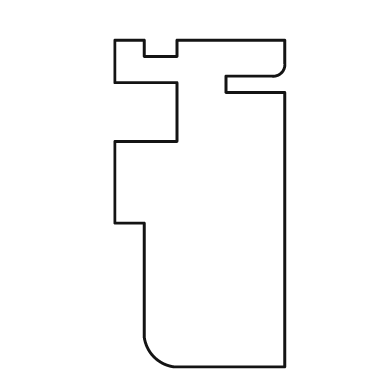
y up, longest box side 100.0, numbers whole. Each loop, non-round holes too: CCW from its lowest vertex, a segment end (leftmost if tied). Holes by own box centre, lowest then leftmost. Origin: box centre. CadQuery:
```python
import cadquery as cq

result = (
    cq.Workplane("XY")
    .moveTo(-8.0, -50.0)
    .lineTo(26.0, -50.0)
    .lineTo(26.0, 34.0)
    .lineTo(8.0, 34.0)
    .lineTo(8.0, 39.0)
    .lineTo(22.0, 39.0)
    .threePointArc((25.0, 40.0), (26.0, 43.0))
    .lineTo(26.0, 50.0)
    .lineTo(-7.0, 50.0)
    .lineTo(-7.0, 45.0)
    .lineTo(-17.0, 45.0)
    .lineTo(-17.0, 50.0)
    .lineTo(-26.0, 50.0)
    .lineTo(-26.0, 37.0)
    .lineTo(-7.0, 37.0)
    .lineTo(-7.0, 19.0)
    .lineTo(-26.0, 19.0)
    .lineTo(-26.0, -6.0)
    .lineTo(-17.0, -6.0)
    .lineTo(-17.0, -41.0)
    .threePointArc((-14.0, -47.0), (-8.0, -50.0))
    .close()
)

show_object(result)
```